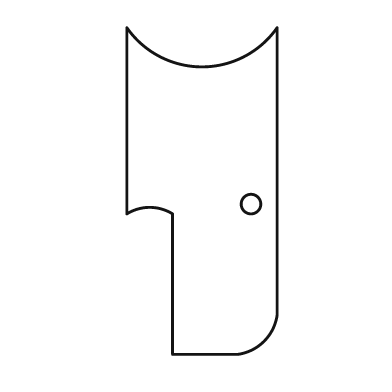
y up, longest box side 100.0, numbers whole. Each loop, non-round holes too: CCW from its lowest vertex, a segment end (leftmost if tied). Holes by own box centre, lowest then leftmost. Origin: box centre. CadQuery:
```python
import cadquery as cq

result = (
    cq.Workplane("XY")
    .moveTo(-9.0, -50.0)
    .lineTo(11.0, -50.0)
    .threePointArc((19.0, -46.0), (23.0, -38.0))
    .lineTo(23.0, 50.0)
    .threePointArc((0.0, 38.0), (-23.0, 50.0))
    .lineTo(-23.0, -7.0)
    .threePointArc((-16.0, -5.0), (-9.0, -7.0))
    .close()
    .moveTo(15.0, -4.0)
    .circle(3.0)
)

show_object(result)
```